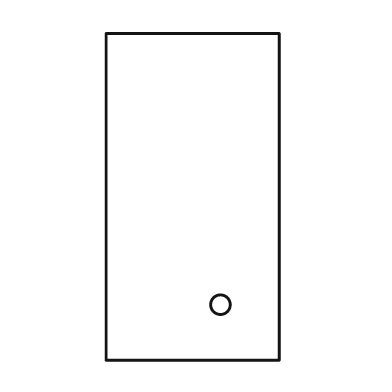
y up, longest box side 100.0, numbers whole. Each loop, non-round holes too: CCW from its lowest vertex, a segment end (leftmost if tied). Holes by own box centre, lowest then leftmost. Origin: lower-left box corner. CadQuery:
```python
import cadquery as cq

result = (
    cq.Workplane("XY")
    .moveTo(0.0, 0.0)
    .lineTo(53.0, 0.0)
    .lineTo(53.0, 100.0)
    .lineTo(0.0, 100.0)
    .close()
    .moveTo(35.0, 17.0)
    .circle(3.0)
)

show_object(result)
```